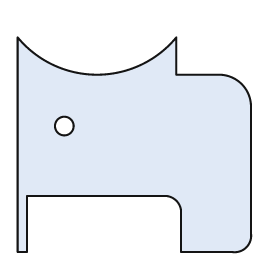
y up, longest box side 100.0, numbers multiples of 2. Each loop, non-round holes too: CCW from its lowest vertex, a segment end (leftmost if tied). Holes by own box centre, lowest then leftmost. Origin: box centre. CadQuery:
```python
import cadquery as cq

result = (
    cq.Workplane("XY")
    .moveTo(-50.0, -46.0)
    .lineTo(-46.0, -46.0)
    .lineTo(-46.0, -22.0)
    .lineTo(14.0, -22.0)
    .threePointArc((18.0, -24.0), (20.0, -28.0))
    .lineTo(20.0, -46.0)
    .lineTo(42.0, -46.0)
    .threePointArc((48.0, -44.0), (50.0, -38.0))
    .lineTo(50.0, 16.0)
    .threePointArc((46.0, 26.0), (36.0, 30.0))
    .lineTo(18.0, 30.0)
    .lineTo(18.0, 46.0)
    .threePointArc((-16.0, 30.0), (-50.0, 46.0))
    .close()
    .moveTo(-30.0, 8.0)
    .circle(4.0)
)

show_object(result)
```